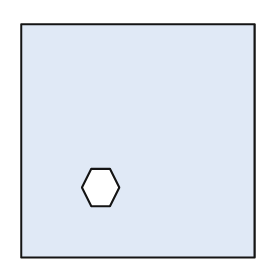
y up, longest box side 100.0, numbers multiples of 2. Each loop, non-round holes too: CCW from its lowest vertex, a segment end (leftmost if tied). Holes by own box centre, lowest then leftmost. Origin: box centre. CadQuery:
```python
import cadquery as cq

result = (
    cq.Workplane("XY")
    .moveTo(-50.0, -50.0)
    .lineTo(50.0, -50.0)
    .lineTo(50.0, 50.0)
    .lineTo(-50.0, 50.0)
    .close()
    .moveTo(-20.0, -28.0)
    .lineTo(-12.0, -28.0)
    .lineTo(-8.0, -20.0)
    .lineTo(-12.0, -12.0)
    .lineTo(-20.0, -12.0)
    .lineTo(-24.0, -20.0)
    .close()
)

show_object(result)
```